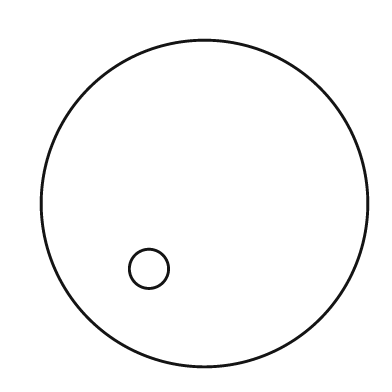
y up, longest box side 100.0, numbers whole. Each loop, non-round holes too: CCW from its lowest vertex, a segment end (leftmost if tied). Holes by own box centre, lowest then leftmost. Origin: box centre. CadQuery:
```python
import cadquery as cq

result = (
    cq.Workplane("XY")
    .moveTo(0.0, 0.0)
    .circle(50.0)
    .moveTo(-17.0, -20.0)
    .circle(6.0)
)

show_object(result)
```